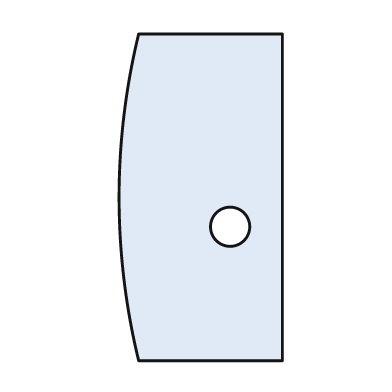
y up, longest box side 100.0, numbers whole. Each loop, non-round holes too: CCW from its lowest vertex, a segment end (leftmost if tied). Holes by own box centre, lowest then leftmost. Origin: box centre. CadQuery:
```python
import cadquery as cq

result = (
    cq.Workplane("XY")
    .moveTo(-19.0, -50.0)
    .lineTo(25.0, -50.0)
    .lineTo(25.0, 50.0)
    .lineTo(-19.0, 50.0)
    .threePointArc((-25.0, 0.0), (-19.0, -50.0))
    .close()
    .moveTo(9.0, -9.0)
    .circle(6.0)
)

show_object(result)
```